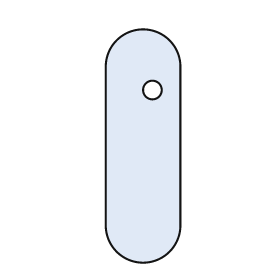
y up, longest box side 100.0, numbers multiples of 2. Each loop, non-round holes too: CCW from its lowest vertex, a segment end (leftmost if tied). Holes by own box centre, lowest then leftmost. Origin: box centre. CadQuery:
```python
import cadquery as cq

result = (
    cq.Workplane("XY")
    .moveTo(-16.0, -34.0)
    .threePointArc((0.0, -50.0), (16.0, -34.0))
    .lineTo(16.0, 34.0)
    .threePointArc((0.0, 50.0), (-16.0, 34.0))
    .close()
    .moveTo(4.0, 24.0)
    .circle(4.0)
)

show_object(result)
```